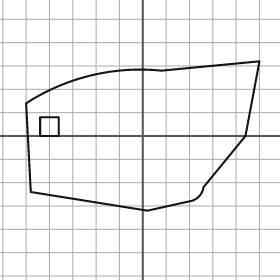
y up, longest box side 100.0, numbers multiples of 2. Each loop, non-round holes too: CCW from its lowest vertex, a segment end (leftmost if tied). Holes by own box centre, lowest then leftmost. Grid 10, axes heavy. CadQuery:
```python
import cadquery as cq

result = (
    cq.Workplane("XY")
    .moveTo(2.0, -32.0)
    .lineTo(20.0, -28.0)
    .threePointArc((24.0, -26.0), (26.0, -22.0))
    .lineTo(44.0, 0.0)
    .lineTo(50.0, 32.0)
    .lineTo(8.0, 28.0)
    .threePointArc((-22.0, 26.0), (-50.0, 14.0))
    .lineTo(-48.0, -24.0)
    .close()
    .moveTo(-44.0, 0.0)
    .lineTo(-36.0, 0.0)
    .lineTo(-36.0, 8.0)
    .lineTo(-44.0, 8.0)
    .close()
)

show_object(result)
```